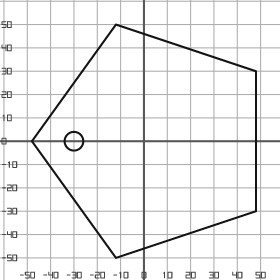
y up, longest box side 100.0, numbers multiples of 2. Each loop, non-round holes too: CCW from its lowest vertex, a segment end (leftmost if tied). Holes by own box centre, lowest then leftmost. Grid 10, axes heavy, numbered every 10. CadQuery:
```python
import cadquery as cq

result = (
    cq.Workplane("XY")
    .moveTo(-12.0, -50.0)
    .lineTo(48.0, -30.0)
    .lineTo(48.0, 30.0)
    .lineTo(-12.0, 50.0)
    .lineTo(-48.0, 0.0)
    .close()
    .moveTo(-30.0, 0.0)
    .circle(4.0)
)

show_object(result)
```